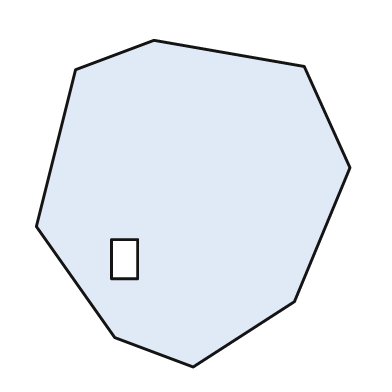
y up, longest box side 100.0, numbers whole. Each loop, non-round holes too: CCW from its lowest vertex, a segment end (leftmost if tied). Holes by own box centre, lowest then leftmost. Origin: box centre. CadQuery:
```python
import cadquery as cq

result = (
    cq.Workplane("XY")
    .moveTo(0.0, -50.0)
    .lineTo(31.0, -30.0)
    .lineTo(48.0, 11.0)
    .lineTo(34.0, 42.0)
    .lineTo(-12.0, 50.0)
    .lineTo(-36.0, 41.0)
    .lineTo(-48.0, -7.0)
    .lineTo(-24.0, -41.0)
    .close()
    .moveTo(-25.0, -23.0)
    .lineTo(-17.0, -23.0)
    .lineTo(-17.0, -11.0)
    .lineTo(-25.0, -11.0)
    .close()
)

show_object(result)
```